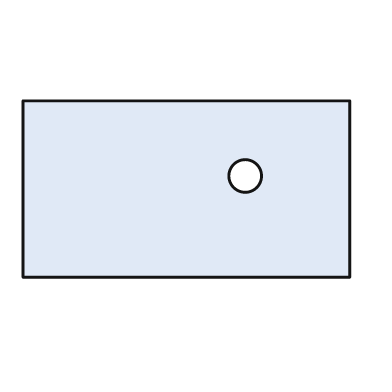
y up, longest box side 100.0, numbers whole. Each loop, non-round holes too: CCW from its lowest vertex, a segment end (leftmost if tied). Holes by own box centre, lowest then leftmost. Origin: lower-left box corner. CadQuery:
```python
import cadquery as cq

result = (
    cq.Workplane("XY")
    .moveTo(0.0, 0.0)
    .lineTo(100.0, 0.0)
    .lineTo(100.0, 54.0)
    .lineTo(0.0, 54.0)
    .close()
    .moveTo(68.0, 31.0)
    .circle(5.0)
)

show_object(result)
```